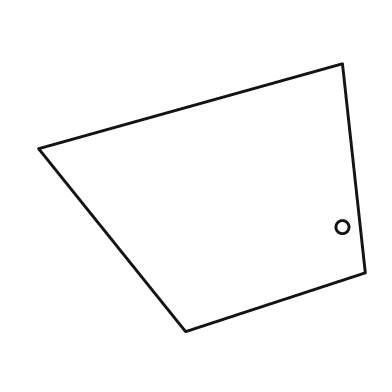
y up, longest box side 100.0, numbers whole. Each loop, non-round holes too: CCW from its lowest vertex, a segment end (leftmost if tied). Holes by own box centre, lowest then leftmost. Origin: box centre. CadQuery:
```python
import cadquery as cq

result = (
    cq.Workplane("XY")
    .moveTo(-5.0, -41.0)
    .lineTo(50.0, -23.0)
    .lineTo(43.0, 41.0)
    .lineTo(-50.0, 15.0)
    .close()
    .moveTo(43.0, -9.0)
    .circle(2.0)
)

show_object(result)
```